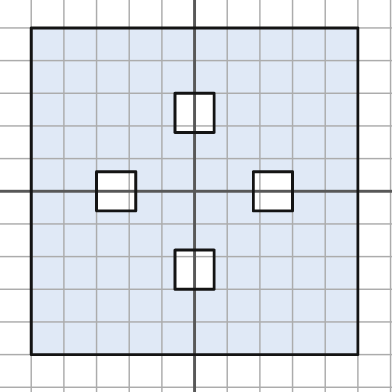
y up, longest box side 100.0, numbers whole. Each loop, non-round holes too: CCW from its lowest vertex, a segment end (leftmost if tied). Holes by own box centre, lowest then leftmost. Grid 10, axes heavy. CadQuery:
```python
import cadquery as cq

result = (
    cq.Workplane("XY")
    .moveTo(-50.0, -50.0)
    .lineTo(50.0, -50.0)
    .lineTo(50.0, 50.0)
    .lineTo(-50.0, 50.0)
    .close()
    .moveTo(-6.0, -30.0)
    .lineTo(6.0, -30.0)
    .lineTo(6.0, -18.0)
    .lineTo(-6.0, -18.0)
    .close()
    .moveTo(-30.0, -6.0)
    .lineTo(-18.0, -6.0)
    .lineTo(-18.0, 6.0)
    .lineTo(-30.0, 6.0)
    .close()
    .moveTo(18.0, -6.0)
    .lineTo(30.0, -6.0)
    .lineTo(30.0, 6.0)
    .lineTo(18.0, 6.0)
    .close()
    .moveTo(-6.0, 18.0)
    .lineTo(6.0, 18.0)
    .lineTo(6.0, 30.0)
    .lineTo(-6.0, 30.0)
    .close()
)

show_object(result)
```